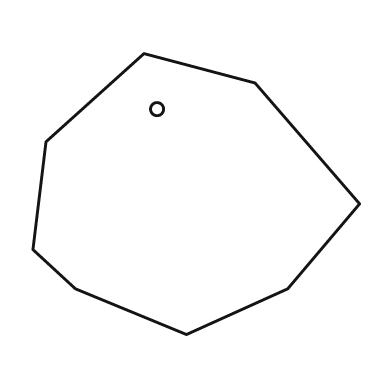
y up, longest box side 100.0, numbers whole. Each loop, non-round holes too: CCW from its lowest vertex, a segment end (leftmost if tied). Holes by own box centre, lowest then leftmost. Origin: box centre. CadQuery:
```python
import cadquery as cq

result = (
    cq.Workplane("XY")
    .moveTo(-3.0, -43.0)
    .lineTo(28.0, -29.0)
    .lineTo(50.0, -3.0)
    .lineTo(18.0, 34.0)
    .lineTo(-16.0, 43.0)
    .lineTo(-46.0, 16.0)
    .lineTo(-50.0, -17.0)
    .lineTo(-37.0, -29.0)
    .close()
    .moveTo(-12.0, 26.0)
    .circle(2.0)
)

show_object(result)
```